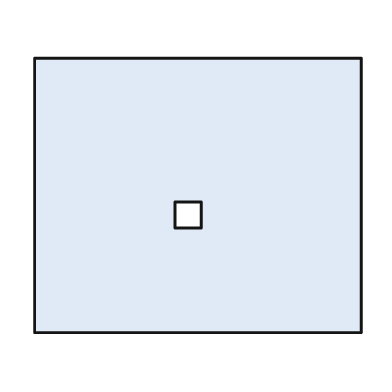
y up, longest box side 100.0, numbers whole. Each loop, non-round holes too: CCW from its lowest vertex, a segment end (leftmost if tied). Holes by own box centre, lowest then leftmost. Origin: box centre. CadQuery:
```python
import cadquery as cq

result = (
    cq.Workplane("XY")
    .moveTo(-50.0, -42.0)
    .lineTo(50.0, -42.0)
    .lineTo(50.0, 42.0)
    .lineTo(-50.0, 42.0)
    .close()
    .moveTo(-7.0, -10.0)
    .lineTo(1.0, -10.0)
    .lineTo(1.0, -2.0)
    .lineTo(-7.0, -2.0)
    .close()
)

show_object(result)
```